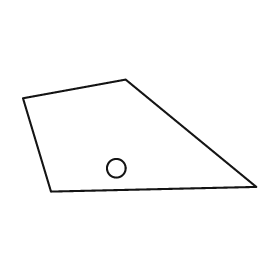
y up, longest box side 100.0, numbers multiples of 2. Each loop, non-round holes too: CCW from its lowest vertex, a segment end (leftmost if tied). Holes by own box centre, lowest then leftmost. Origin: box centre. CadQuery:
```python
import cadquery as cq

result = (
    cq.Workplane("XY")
    .moveTo(-38.0, -24.0)
    .lineTo(50.0, -22.0)
    .lineTo(-6.0, 24.0)
    .lineTo(-50.0, 16.0)
    .close()
    .moveTo(-10.0, -14.0)
    .circle(4.0)
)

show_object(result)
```